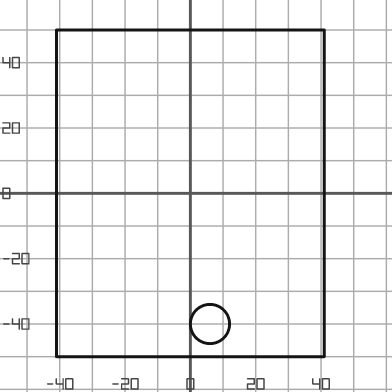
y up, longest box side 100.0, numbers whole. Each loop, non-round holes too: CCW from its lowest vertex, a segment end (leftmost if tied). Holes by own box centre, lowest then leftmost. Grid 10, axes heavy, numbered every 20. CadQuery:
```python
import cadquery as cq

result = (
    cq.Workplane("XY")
    .moveTo(-41.0, -50.0)
    .lineTo(41.0, -50.0)
    .lineTo(41.0, 50.0)
    .lineTo(-41.0, 50.0)
    .close()
    .moveTo(6.0, -40.0)
    .circle(6.0)
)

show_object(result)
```